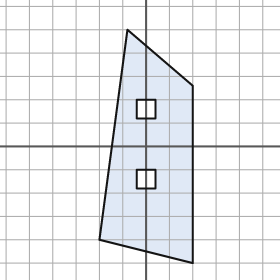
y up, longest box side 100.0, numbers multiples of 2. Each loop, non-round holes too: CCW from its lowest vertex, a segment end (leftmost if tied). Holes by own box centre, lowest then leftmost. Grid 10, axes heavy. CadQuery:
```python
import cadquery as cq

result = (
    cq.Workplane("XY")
    .moveTo(20.0, -50.0)
    .lineTo(20.0, 26.0)
    .lineTo(-8.0, 50.0)
    .lineTo(-20.0, -40.0)
    .close()
    .moveTo(-4.0, -18.0)
    .lineTo(4.0, -18.0)
    .lineTo(4.0, -10.0)
    .lineTo(-4.0, -10.0)
    .close()
    .moveTo(-4.0, 12.0)
    .lineTo(4.0, 12.0)
    .lineTo(4.0, 20.0)
    .lineTo(-4.0, 20.0)
    .close()
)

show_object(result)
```